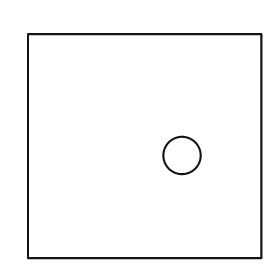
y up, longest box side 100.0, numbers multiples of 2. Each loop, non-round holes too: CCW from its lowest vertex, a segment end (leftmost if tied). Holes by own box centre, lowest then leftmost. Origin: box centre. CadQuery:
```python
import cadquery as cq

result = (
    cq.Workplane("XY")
    .moveTo(-50.0, -48.0)
    .lineTo(50.0, -48.0)
    .lineTo(50.0, 48.0)
    .lineTo(-50.0, 48.0)
    .close()
    .moveTo(16.0, -4.0)
    .circle(8.0)
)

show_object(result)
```